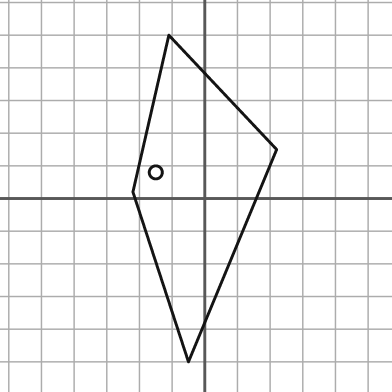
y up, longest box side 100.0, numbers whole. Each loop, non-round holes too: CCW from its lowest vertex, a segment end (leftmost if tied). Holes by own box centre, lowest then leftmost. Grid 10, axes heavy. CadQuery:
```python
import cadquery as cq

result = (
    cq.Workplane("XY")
    .moveTo(-5.0, -50.0)
    .lineTo(22.0, 15.0)
    .lineTo(-11.0, 50.0)
    .lineTo(-22.0, 2.0)
    .close()
    .moveTo(-15.0, 8.0)
    .circle(2.0)
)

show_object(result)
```